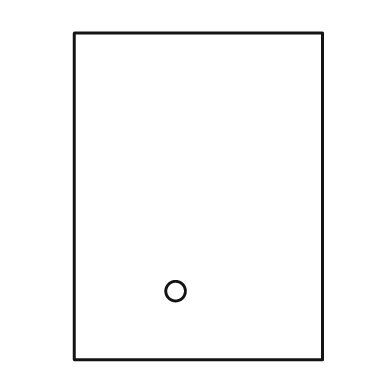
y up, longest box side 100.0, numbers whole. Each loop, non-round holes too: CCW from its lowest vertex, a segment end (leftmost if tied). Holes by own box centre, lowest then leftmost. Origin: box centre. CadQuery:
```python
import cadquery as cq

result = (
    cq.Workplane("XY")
    .moveTo(-38.0, -50.0)
    .lineTo(38.0, -50.0)
    .lineTo(38.0, 50.0)
    .lineTo(-38.0, 50.0)
    .close()
    .moveTo(-7.0, -29.0)
    .circle(3.0)
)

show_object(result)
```